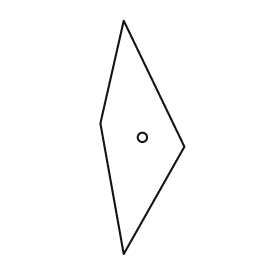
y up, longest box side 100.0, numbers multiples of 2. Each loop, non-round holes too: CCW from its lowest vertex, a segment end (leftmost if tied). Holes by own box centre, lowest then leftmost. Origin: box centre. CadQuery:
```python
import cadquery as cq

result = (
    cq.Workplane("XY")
    .moveTo(-8.0, -50.0)
    .lineTo(18.0, -4.0)
    .lineTo(-8.0, 50.0)
    .lineTo(-18.0, 6.0)
    .close()
    .moveTo(0.0, 0.0)
    .circle(2.0)
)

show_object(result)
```